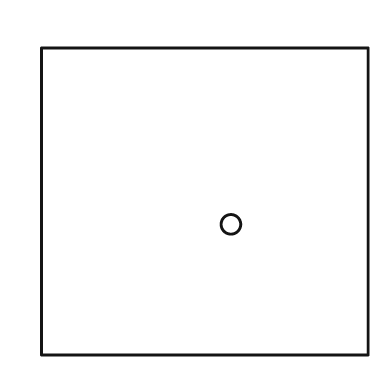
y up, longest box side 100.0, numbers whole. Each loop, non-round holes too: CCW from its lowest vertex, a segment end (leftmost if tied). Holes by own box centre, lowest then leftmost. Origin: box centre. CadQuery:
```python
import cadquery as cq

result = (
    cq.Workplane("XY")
    .moveTo(-50.0, -47.0)
    .lineTo(50.0, -47.0)
    .lineTo(50.0, 47.0)
    .lineTo(-50.0, 47.0)
    .close()
    .moveTo(8.0, -7.0)
    .circle(3.0)
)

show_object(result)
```